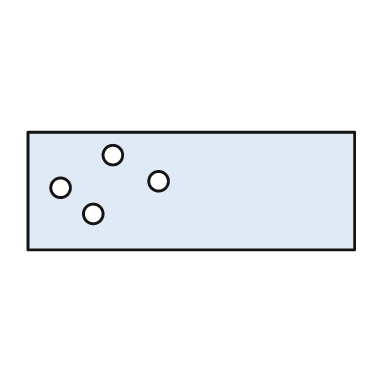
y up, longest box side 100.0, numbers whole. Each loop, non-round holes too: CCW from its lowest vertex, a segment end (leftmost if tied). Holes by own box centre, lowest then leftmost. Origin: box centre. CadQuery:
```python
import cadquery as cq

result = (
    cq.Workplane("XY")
    .moveTo(-50.0, -18.0)
    .lineTo(50.0, -18.0)
    .lineTo(50.0, 18.0)
    .lineTo(-50.0, 18.0)
    .close()
    .moveTo(-30.0, -7.0)
    .circle(3.0)
    .moveTo(-40.0, 1.0)
    .circle(3.0)
    .moveTo(-10.0, 3.0)
    .circle(3.0)
    .moveTo(-24.0, 11.0)
    .circle(3.0)
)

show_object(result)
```